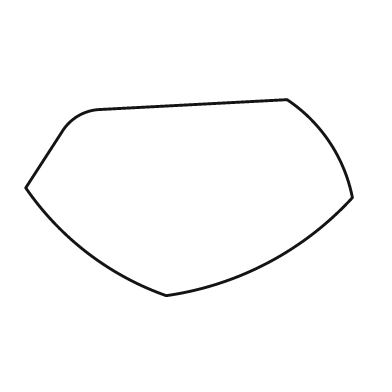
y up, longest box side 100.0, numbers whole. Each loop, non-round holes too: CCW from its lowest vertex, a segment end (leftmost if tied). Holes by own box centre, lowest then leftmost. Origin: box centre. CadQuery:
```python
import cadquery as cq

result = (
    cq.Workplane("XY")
    .moveTo(-7.0, -30.0)
    .threePointArc((24.0, -20.0), (50.0, 0.0))
    .threePointArc((43.0, 17.0), (30.0, 30.0))
    .lineTo(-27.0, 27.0)
    .threePointArc((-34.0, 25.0), (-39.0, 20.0))
    .lineTo(-50.0, 3.0)
    .threePointArc((-31.0, -17.0), (-7.0, -30.0))
    .close()
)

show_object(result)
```